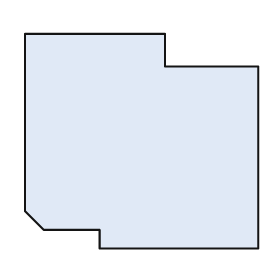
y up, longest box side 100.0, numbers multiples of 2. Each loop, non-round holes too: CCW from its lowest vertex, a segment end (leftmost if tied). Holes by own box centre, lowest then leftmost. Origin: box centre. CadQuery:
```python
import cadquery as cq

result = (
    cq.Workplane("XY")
    .moveTo(-18.0, -46.0)
    .lineTo(50.0, -46.0)
    .lineTo(50.0, 32.0)
    .lineTo(10.0, 32.0)
    .lineTo(10.0, 46.0)
    .lineTo(-50.0, 46.0)
    .lineTo(-50.0, -30.0)
    .lineTo(-42.0, -38.0)
    .lineTo(-18.0, -38.0)
    .close()
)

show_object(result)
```